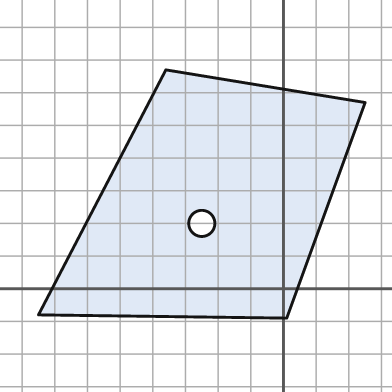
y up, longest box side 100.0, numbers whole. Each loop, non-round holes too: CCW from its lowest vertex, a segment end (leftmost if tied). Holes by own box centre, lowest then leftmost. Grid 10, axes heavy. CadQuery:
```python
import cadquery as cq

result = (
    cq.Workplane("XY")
    .moveTo(1.0, -9.0)
    .lineTo(25.0, 57.0)
    .lineTo(-36.0, 67.0)
    .lineTo(-75.0, -8.0)
    .close()
    .moveTo(-25.0, 20.0)
    .circle(4.0)
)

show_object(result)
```